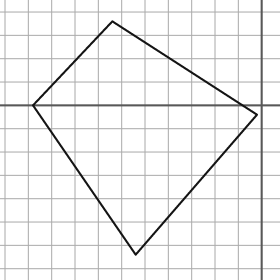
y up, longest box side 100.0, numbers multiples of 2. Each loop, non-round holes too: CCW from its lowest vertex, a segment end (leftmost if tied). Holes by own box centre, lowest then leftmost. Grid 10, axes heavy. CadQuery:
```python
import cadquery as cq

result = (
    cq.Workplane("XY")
    .moveTo(-54.0, -64.0)
    .lineTo(-2.0, -4.0)
    .lineTo(-64.0, 36.0)
    .lineTo(-98.0, 0.0)
    .close()
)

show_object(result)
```